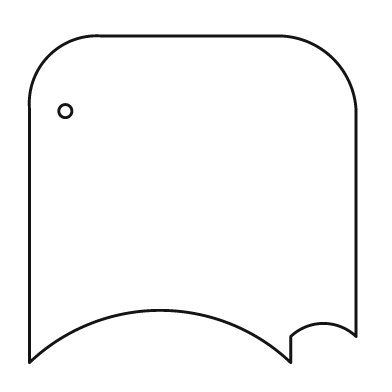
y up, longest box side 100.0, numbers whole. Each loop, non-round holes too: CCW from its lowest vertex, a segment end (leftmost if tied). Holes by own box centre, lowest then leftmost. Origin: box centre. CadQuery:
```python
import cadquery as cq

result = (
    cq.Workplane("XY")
    .moveTo(-50.0, -50.0)
    .threePointArc((-10.0, -34.0), (30.0, -50.0))
    .lineTo(30.0, -42.0)
    .threePointArc((40.0, -38.0), (50.0, -42.0))
    .lineTo(50.0, 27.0)
    .threePointArc((43.0, 43.0), (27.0, 50.0))
    .lineTo(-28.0, 50.0)
    .threePointArc((-44.0, 44.0), (-50.0, 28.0))
    .close()
    .moveTo(-39.0, 27.0)
    .circle(2.0)
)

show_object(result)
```